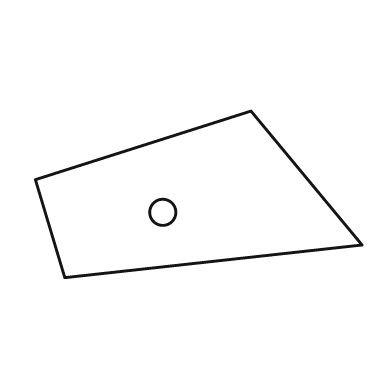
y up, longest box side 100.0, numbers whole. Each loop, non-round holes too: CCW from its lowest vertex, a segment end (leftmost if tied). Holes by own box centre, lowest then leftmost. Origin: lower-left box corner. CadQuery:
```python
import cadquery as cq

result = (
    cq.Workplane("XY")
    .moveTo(9.0, 0.0)
    .lineTo(100.0, 10.0)
    .lineTo(66.0, 51.0)
    .lineTo(0.0, 30.0)
    .close()
    .moveTo(39.0, 20.0)
    .circle(4.0)
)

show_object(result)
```